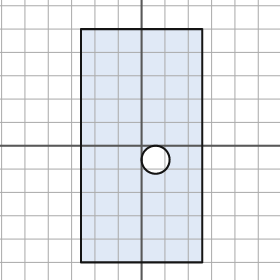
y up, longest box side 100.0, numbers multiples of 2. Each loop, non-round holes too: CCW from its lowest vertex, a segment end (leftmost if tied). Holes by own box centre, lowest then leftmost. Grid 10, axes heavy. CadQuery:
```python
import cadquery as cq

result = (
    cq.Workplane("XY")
    .moveTo(-26.0, -50.0)
    .lineTo(26.0, -50.0)
    .lineTo(26.0, 50.0)
    .lineTo(-26.0, 50.0)
    .close()
    .moveTo(6.0, -6.0)
    .circle(6.0)
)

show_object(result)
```